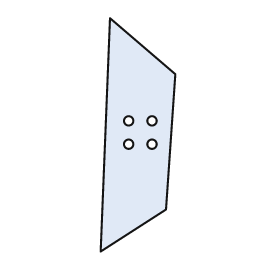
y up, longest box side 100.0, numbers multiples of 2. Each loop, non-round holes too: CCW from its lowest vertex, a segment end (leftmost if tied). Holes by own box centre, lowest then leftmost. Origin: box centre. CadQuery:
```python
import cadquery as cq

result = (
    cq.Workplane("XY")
    .moveTo(-16.0, -50.0)
    .lineTo(12.0, -32.0)
    .lineTo(16.0, 26.0)
    .lineTo(-12.0, 50.0)
    .close()
    .moveTo(-4.0, -4.0)
    .circle(2.0)
    .moveTo(6.0, -4.0)
    .circle(2.0)
    .moveTo(-4.0, 6.0)
    .circle(2.0)
    .moveTo(6.0, 6.0)
    .circle(2.0)
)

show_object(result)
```